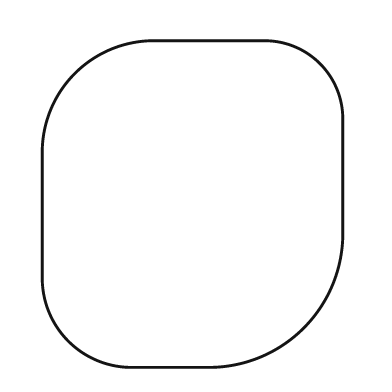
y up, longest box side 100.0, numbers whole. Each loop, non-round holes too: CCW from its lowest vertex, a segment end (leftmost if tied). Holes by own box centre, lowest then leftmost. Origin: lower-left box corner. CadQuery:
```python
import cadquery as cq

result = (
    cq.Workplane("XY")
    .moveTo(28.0, 0.0)
    .lineTo(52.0, 0.0)
    .threePointArc((80.0, 12.0), (92.0, 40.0))
    .lineTo(92.0, 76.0)
    .threePointArc((85.0, 93.0), (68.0, 100.0))
    .lineTo(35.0, 100.0)
    .threePointArc((10.0, 90.0), (0.0, 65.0))
    .lineTo(0.0, 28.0)
    .threePointArc((8.0, 8.0), (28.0, 0.0))
    .close()
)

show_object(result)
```